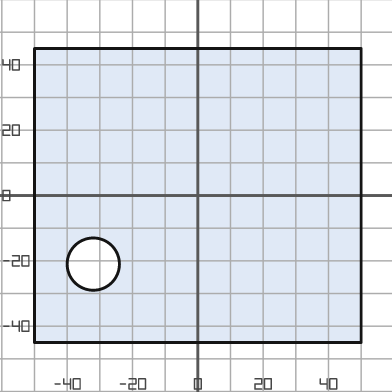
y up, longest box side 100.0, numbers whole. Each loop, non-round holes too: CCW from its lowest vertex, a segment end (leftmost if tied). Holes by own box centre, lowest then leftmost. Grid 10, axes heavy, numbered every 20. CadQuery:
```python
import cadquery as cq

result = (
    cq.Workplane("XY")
    .moveTo(-50.0, -45.0)
    .lineTo(50.0, -45.0)
    .lineTo(50.0, 45.0)
    .lineTo(-50.0, 45.0)
    .close()
    .moveTo(-32.0, -21.0)
    .circle(8.0)
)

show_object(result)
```